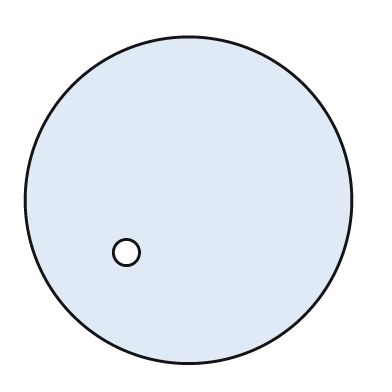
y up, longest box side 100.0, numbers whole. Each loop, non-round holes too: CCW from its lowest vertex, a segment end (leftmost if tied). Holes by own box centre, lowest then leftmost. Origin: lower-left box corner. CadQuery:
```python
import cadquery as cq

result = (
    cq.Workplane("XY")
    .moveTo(50.0, 50.0)
    .circle(50.0)
    .moveTo(31.0, 34.0)
    .circle(4.0)
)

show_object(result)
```